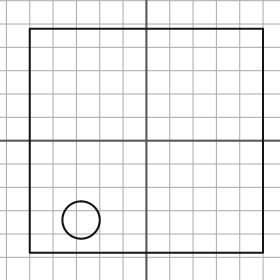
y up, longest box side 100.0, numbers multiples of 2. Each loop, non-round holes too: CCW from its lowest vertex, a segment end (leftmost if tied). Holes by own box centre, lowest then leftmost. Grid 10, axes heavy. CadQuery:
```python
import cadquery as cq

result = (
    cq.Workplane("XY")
    .moveTo(-50.0, -48.0)
    .lineTo(50.0, -48.0)
    .lineTo(50.0, 48.0)
    .lineTo(-50.0, 48.0)
    .close()
    .moveTo(-28.0, -34.0)
    .circle(8.0)
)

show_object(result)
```